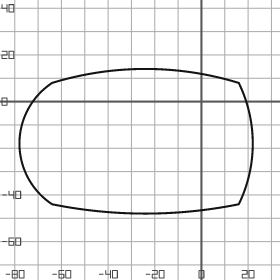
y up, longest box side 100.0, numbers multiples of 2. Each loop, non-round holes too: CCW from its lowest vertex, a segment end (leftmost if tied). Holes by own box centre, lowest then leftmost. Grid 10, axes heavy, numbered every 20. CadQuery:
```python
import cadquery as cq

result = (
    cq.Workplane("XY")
    .moveTo(-64.0, -44.0)
    .threePointArc((-24.0, -48.0), (16.0, -44.0))
    .threePointArc((22.0, -18.0), (16.0, 8.0))
    .threePointArc((-24.0, 14.0), (-64.0, 8.0))
    .threePointArc((-78.0, -18.0), (-64.0, -44.0))
    .close()
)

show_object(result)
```